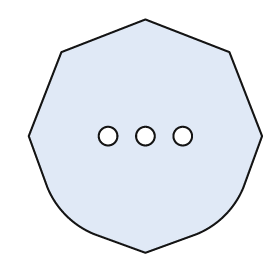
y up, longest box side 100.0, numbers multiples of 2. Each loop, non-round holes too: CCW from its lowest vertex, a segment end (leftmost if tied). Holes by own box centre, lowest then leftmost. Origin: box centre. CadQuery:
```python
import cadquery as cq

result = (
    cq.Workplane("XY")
    .moveTo(0.0, -50.0)
    .lineTo(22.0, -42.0)
    .threePointArc((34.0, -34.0), (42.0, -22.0))
    .lineTo(50.0, 0.0)
    .lineTo(36.0, 36.0)
    .lineTo(0.0, 50.0)
    .lineTo(-36.0, 36.0)
    .lineTo(-50.0, 0.0)
    .lineTo(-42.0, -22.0)
    .threePointArc((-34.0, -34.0), (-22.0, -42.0))
    .close()
    .moveTo(-16.0, 0.0)
    .circle(4.0)
    .moveTo(0.0, 0.0)
    .circle(4.0)
    .moveTo(16.0, 0.0)
    .circle(4.0)
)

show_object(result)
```